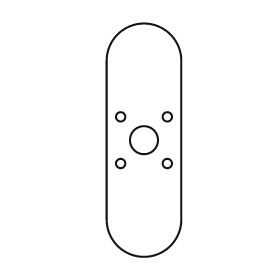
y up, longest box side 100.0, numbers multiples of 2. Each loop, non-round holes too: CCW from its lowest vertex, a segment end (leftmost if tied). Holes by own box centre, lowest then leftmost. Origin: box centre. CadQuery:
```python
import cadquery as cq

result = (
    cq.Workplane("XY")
    .moveTo(-16.0, -34.0)
    .threePointArc((0.0, -50.0), (16.0, -34.0))
    .lineTo(16.0, 34.0)
    .threePointArc((0.0, 50.0), (-16.0, 34.0))
    .close()
    .moveTo(-10.0, -10.0)
    .circle(2.0)
    .moveTo(10.0, -10.0)
    .circle(2.0)
    .moveTo(0.0, 0.0)
    .circle(6.0)
    .moveTo(-10.0, 10.0)
    .circle(2.0)
    .moveTo(10.0, 10.0)
    .circle(2.0)
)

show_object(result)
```